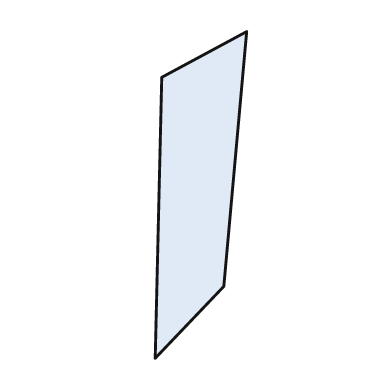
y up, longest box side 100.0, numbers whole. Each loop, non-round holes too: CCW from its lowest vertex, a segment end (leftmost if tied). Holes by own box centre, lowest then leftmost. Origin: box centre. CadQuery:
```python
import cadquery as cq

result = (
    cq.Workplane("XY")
    .moveTo(-14.0, -50.0)
    .lineTo(7.0, -28.0)
    .lineTo(14.0, 50.0)
    .lineTo(-12.0, 36.0)
    .close()
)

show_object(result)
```